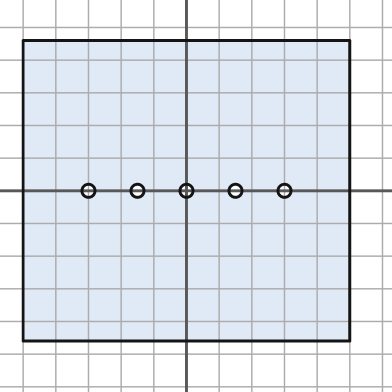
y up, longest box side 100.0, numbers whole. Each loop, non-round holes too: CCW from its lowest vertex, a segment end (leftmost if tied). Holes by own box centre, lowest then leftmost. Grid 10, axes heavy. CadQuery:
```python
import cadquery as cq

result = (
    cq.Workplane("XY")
    .moveTo(-50.0, -46.0)
    .lineTo(50.0, -46.0)
    .lineTo(50.0, 46.0)
    .lineTo(-50.0, 46.0)
    .close()
    .moveTo(-30.0, 0.0)
    .circle(2.0)
    .moveTo(-15.0, 0.0)
    .circle(2.0)
    .moveTo(0.0, 0.0)
    .circle(2.0)
    .moveTo(15.0, 0.0)
    .circle(2.0)
    .moveTo(30.0, 0.0)
    .circle(2.0)
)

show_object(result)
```